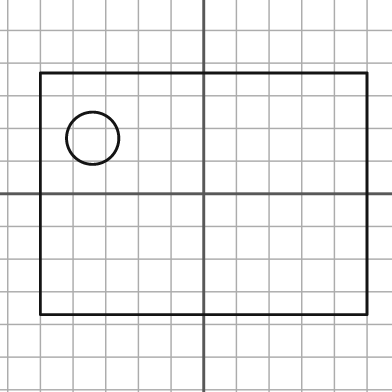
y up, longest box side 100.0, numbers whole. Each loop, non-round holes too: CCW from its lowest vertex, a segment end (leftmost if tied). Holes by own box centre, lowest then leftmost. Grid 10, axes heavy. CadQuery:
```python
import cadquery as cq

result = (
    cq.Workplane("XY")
    .moveTo(-50.0, -37.0)
    .lineTo(50.0, -37.0)
    .lineTo(50.0, 37.0)
    .lineTo(-50.0, 37.0)
    .close()
    .moveTo(-34.0, 17.0)
    .circle(8.0)
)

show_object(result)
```